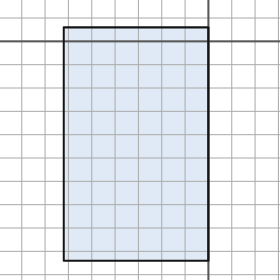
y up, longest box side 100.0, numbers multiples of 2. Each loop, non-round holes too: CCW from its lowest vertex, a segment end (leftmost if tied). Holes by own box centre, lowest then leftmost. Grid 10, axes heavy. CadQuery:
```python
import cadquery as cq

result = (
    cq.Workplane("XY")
    .moveTo(-62.0, -94.0)
    .lineTo(0.0, -94.0)
    .lineTo(0.0, 6.0)
    .lineTo(-62.0, 6.0)
    .close()
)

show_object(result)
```